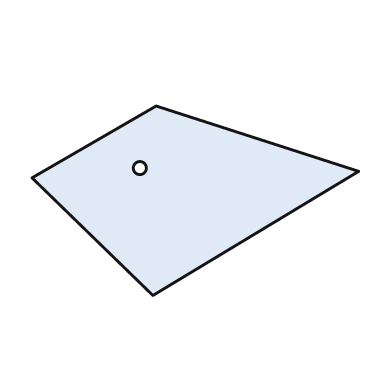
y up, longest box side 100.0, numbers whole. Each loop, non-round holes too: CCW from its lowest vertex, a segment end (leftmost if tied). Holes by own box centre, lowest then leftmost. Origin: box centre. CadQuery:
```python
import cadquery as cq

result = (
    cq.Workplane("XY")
    .moveTo(-13.0, -29.0)
    .lineTo(50.0, 9.0)
    .lineTo(-12.0, 29.0)
    .lineTo(-50.0, 7.0)
    .close()
    .moveTo(-17.0, 10.0)
    .circle(2.0)
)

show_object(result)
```